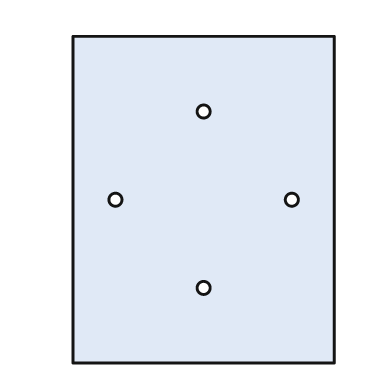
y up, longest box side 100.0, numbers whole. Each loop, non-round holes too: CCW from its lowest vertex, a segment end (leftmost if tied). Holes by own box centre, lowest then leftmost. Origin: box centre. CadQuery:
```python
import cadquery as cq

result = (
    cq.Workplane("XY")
    .moveTo(-40.0, -50.0)
    .lineTo(40.0, -50.0)
    .lineTo(40.0, 50.0)
    .lineTo(-40.0, 50.0)
    .close()
    .moveTo(0.0, -27.0)
    .circle(2.0)
    .moveTo(-27.0, 0.0)
    .circle(2.0)
    .moveTo(27.0, 0.0)
    .circle(2.0)
    .moveTo(0.0, 27.0)
    .circle(2.0)
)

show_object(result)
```